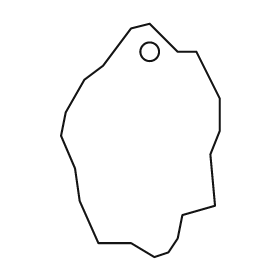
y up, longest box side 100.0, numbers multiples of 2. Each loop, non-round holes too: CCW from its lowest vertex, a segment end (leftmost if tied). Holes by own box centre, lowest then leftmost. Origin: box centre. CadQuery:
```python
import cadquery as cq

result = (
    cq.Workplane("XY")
    .moveTo(6.0, -50.0)
    .lineTo(12.0, -48.0)
    .lineTo(16.0, -42.0)
    .lineTo(18.0, -32.0)
    .lineTo(32.0, -28.0)
    .lineTo(30.0, -6.0)
    .lineTo(34.0, 4.0)
    .lineTo(34.0, 18.0)
    .lineTo(24.0, 38.0)
    .lineTo(16.0, 38.0)
    .lineTo(4.0, 50.0)
    .lineTo(-4.0, 48.0)
    .lineTo(-16.0, 32.0)
    .lineTo(-24.0, 26.0)
    .lineTo(-32.0, 12.0)
    .lineTo(-34.0, 2.0)
    .lineTo(-28.0, -12.0)
    .lineTo(-26.0, -26.0)
    .lineTo(-18.0, -44.0)
    .lineTo(-4.0, -44.0)
    .close()
    .moveTo(4.0, 38.0)
    .circle(4.0)
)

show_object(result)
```